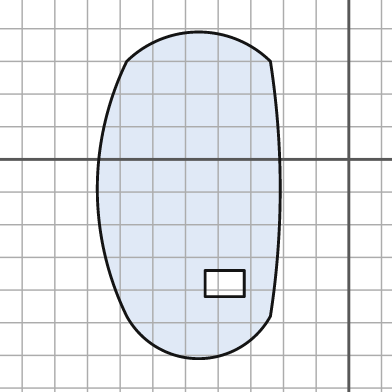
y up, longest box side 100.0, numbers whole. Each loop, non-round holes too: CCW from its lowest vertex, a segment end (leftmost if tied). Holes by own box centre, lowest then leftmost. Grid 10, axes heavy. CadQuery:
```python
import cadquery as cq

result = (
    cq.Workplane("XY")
    .moveTo(-68.0, -48.0)
    .threePointArc((-46.0, -61.0), (-24.0, -48.0))
    .threePointArc((-21.0, -9.0), (-24.0, 30.0))
    .threePointArc((-46.0, 39.0), (-68.0, 30.0))
    .threePointArc((-77.0, -9.0), (-68.0, -48.0))
    .close()
    .moveTo(-44.0, -42.0)
    .lineTo(-32.0, -42.0)
    .lineTo(-32.0, -34.0)
    .lineTo(-44.0, -34.0)
    .close()
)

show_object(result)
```